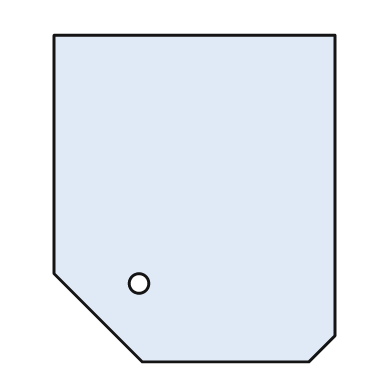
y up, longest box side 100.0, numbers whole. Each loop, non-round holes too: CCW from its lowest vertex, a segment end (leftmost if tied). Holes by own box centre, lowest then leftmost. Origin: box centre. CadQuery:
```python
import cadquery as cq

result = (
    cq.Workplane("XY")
    .moveTo(-16.0, -50.0)
    .lineTo(35.0, -50.0)
    .lineTo(43.0, -42.0)
    .lineTo(43.0, 50.0)
    .lineTo(-43.0, 50.0)
    .lineTo(-43.0, -23.0)
    .close()
    .moveTo(-17.0, -26.0)
    .circle(3.0)
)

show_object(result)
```